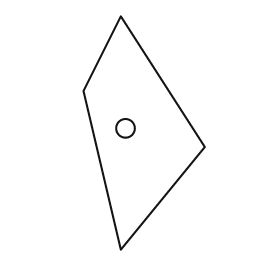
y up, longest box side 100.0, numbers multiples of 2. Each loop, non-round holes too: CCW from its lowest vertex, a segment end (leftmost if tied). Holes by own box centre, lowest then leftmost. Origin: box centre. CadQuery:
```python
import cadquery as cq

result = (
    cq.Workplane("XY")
    .moveTo(-10.0, -50.0)
    .lineTo(26.0, -6.0)
    .lineTo(-10.0, 50.0)
    .lineTo(-26.0, 18.0)
    .close()
    .moveTo(-8.0, 2.0)
    .circle(4.0)
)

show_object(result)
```